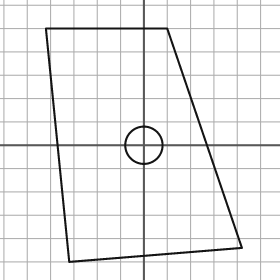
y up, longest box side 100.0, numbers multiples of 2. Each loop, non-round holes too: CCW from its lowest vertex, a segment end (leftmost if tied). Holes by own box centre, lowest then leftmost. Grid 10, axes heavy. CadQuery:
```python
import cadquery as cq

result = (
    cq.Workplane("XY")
    .moveTo(-32.0, -50.0)
    .lineTo(42.0, -44.0)
    .lineTo(10.0, 50.0)
    .lineTo(-42.0, 50.0)
    .close()
    .moveTo(0.0, 0.0)
    .circle(8.0)
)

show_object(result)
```